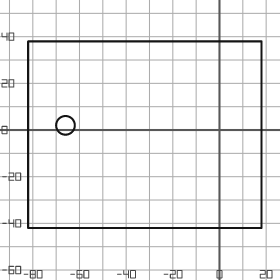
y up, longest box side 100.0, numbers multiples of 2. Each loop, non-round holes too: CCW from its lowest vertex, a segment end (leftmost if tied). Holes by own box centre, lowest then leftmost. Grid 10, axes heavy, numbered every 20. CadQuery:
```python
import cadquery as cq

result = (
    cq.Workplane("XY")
    .moveTo(-82.0, -42.0)
    .lineTo(18.0, -42.0)
    .lineTo(18.0, 38.0)
    .lineTo(-82.0, 38.0)
    .close()
    .moveTo(-66.0, 2.0)
    .circle(4.0)
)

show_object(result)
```